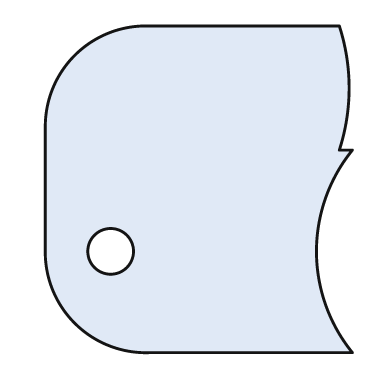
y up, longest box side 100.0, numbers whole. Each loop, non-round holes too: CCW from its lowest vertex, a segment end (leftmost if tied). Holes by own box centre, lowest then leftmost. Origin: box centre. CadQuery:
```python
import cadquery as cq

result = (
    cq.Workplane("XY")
    .moveTo(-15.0, -50.0)
    .lineTo(47.0, -50.0)
    .threePointArc((36.0, -19.0), (47.0, 12.0))
    .lineTo(43.0, 12.0)
    .threePointArc((46.0, 31.0), (43.0, 50.0))
    .lineTo(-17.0, 50.0)
    .threePointArc((-38.0, 41.0), (-47.0, 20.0))
    .lineTo(-47.0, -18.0)
    .threePointArc((-38.0, -41.0), (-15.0, -50.0))
    .close()
    .moveTo(-27.0, -19.0)
    .circle(7.0)
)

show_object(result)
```